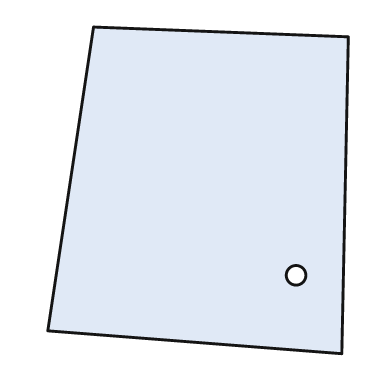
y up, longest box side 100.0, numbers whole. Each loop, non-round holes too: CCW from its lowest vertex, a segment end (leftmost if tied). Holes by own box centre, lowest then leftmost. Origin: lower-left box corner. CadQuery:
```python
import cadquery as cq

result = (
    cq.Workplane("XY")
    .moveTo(90.0, 0.0)
    .lineTo(92.0, 97.0)
    .lineTo(14.0, 100.0)
    .lineTo(0.0, 7.0)
    .close()
    .moveTo(76.0, 24.0)
    .circle(3.0)
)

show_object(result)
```